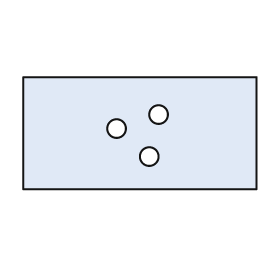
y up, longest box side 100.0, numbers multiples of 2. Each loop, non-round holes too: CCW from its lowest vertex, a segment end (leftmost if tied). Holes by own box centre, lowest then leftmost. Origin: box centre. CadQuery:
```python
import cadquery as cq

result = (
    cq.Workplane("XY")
    .moveTo(-50.0, -24.0)
    .lineTo(50.0, -24.0)
    .lineTo(50.0, 24.0)
    .lineTo(-50.0, 24.0)
    .close()
    .moveTo(4.0, -10.0)
    .circle(4.0)
    .moveTo(-10.0, 2.0)
    .circle(4.0)
    .moveTo(8.0, 8.0)
    .circle(4.0)
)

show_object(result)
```